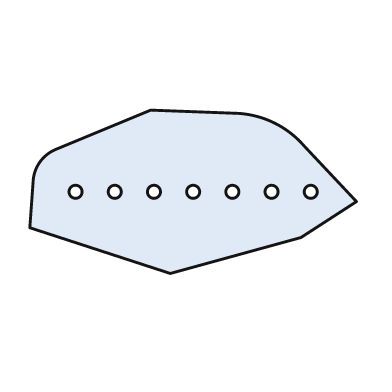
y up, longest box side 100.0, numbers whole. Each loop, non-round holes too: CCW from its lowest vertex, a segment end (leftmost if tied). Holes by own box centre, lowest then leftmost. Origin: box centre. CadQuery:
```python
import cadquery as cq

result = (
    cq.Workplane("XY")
    .moveTo(-7.0, -25.0)
    .lineTo(33.0, -14.0)
    .lineTo(50.0, -3.0)
    .lineTo(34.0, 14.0)
    .threePointArc((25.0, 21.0), (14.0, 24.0))
    .lineTo(-13.0, 25.0)
    .lineTo(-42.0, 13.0)
    .threePointArc((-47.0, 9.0), (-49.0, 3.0))
    .lineTo(-50.0, -11.0)
    .close()
    .moveTo(-36.0, 0.0)
    .circle(2.0)
    .moveTo(-24.0, 0.0)
    .circle(2.0)
    .moveTo(-12.0, 0.0)
    .circle(2.0)
    .moveTo(0.0, 0.0)
    .circle(2.0)
    .moveTo(12.0, 0.0)
    .circle(2.0)
    .moveTo(24.0, 0.0)
    .circle(2.0)
    .moveTo(36.0, 0.0)
    .circle(2.0)
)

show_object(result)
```